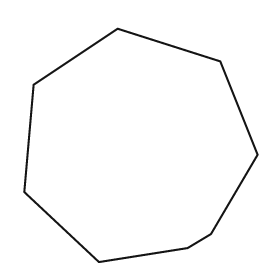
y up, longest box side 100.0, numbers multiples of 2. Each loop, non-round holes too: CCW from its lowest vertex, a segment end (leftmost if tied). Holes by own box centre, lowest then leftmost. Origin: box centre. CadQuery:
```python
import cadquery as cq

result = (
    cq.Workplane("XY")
    .moveTo(-18.0, -50.0)
    .lineTo(20.0, -44.0)
    .lineTo(30.0, -38.0)
    .lineTo(50.0, -4.0)
    .lineTo(34.0, 36.0)
    .lineTo(-10.0, 50.0)
    .lineTo(-46.0, 26.0)
    .lineTo(-50.0, -20.0)
    .close()
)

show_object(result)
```